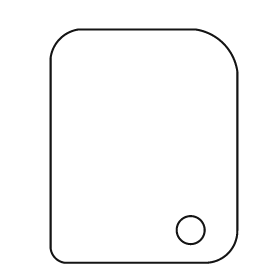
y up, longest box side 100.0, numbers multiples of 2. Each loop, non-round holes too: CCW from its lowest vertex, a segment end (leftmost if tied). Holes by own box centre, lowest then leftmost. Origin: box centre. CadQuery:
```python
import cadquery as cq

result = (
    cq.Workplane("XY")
    .moveTo(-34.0, -50.0)
    .lineTo(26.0, -50.0)
    .threePointArc((36.0, -46.0), (40.0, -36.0))
    .lineTo(40.0, 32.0)
    .threePointArc((34.0, 44.0), (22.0, 50.0))
    .lineTo(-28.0, 50.0)
    .threePointArc((-36.0, 46.0), (-40.0, 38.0))
    .lineTo(-40.0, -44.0)
    .threePointArc((-38.0, -48.0), (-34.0, -50.0))
    .close()
    .moveTo(20.0, -36.0)
    .circle(6.0)
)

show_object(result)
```